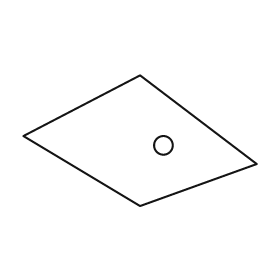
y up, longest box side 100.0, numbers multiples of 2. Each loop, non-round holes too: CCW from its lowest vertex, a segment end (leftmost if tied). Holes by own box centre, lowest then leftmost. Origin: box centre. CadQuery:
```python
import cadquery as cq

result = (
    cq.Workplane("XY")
    .moveTo(0.0, -28.0)
    .lineTo(50.0, -10.0)
    .lineTo(0.0, 28.0)
    .lineTo(-50.0, 2.0)
    .close()
    .moveTo(10.0, -2.0)
    .circle(4.0)
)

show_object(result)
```